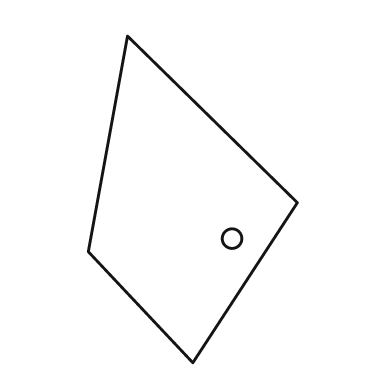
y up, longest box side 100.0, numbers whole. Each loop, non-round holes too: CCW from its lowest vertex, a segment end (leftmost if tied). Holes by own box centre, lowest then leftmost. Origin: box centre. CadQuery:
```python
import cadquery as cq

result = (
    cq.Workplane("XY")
    .moveTo(0.0, -50.0)
    .lineTo(32.0, -1.0)
    .lineTo(-20.0, 50.0)
    .lineTo(-32.0, -16.0)
    .close()
    .moveTo(12.0, -12.0)
    .circle(3.0)
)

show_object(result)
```